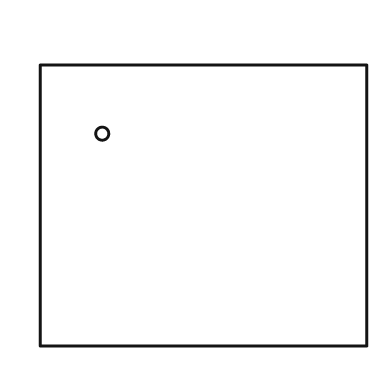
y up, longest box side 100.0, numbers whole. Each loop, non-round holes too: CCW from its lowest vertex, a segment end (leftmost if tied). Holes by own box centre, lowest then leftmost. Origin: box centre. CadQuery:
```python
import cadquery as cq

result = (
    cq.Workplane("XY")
    .moveTo(-50.0, -43.0)
    .lineTo(50.0, -43.0)
    .lineTo(50.0, 43.0)
    .lineTo(-50.0, 43.0)
    .close()
    .moveTo(-31.0, 22.0)
    .circle(2.0)
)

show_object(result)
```